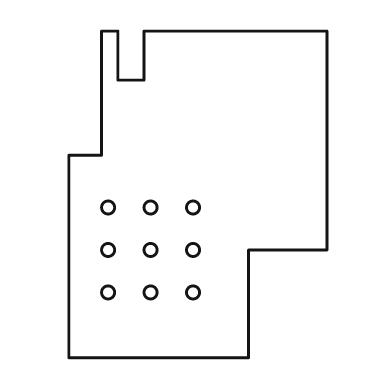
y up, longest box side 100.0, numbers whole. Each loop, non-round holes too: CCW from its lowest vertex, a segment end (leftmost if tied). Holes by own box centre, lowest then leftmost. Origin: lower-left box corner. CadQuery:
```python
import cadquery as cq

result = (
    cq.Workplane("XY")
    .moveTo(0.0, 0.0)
    .lineTo(55.0, 0.0)
    .lineTo(55.0, 33.0)
    .lineTo(79.0, 33.0)
    .lineTo(79.0, 100.0)
    .lineTo(23.0, 100.0)
    .lineTo(23.0, 85.0)
    .lineTo(15.0, 85.0)
    .lineTo(15.0, 100.0)
    .lineTo(10.0, 100.0)
    .lineTo(10.0, 62.0)
    .lineTo(0.0, 62.0)
    .close()
    .moveTo(12.0, 20.0)
    .circle(2.0)
    .moveTo(25.0, 20.0)
    .circle(2.0)
    .moveTo(38.0, 20.0)
    .circle(2.0)
    .moveTo(12.0, 33.0)
    .circle(2.0)
    .moveTo(25.0, 33.0)
    .circle(2.0)
    .moveTo(38.0, 33.0)
    .circle(2.0)
    .moveTo(12.0, 46.0)
    .circle(2.0)
    .moveTo(25.0, 46.0)
    .circle(2.0)
    .moveTo(38.0, 46.0)
    .circle(2.0)
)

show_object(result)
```